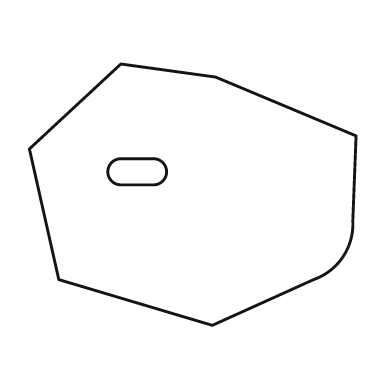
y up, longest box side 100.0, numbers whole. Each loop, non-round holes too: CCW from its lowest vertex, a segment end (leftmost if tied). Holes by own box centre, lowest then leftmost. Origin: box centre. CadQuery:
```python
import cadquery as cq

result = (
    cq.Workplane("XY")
    .moveTo(6.0, -40.0)
    .lineTo(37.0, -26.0)
    .threePointArc((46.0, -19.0), (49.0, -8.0))
    .lineTo(50.0, 18.0)
    .lineTo(7.0, 36.0)
    .lineTo(-22.0, 40.0)
    .lineTo(-50.0, 14.0)
    .lineTo(-41.0, -26.0)
    .close()
    .moveTo(-22.0, 3.0)
    .lineTo(-12.0, 3.0)
    .threePointArc((-8.0, 7.0), (-12.0, 11.0))
    .lineTo(-22.0, 11.0)
    .threePointArc((-26.0, 7.0), (-22.0, 3.0))
    .close()
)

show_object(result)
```